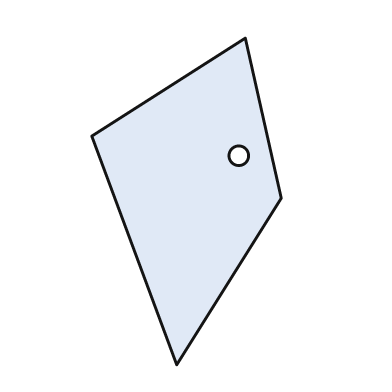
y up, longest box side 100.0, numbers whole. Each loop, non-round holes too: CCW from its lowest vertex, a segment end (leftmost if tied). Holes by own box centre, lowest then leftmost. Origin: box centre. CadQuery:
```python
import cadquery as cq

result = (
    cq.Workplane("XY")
    .moveTo(-3.0, -50.0)
    .lineTo(29.0, 1.0)
    .lineTo(18.0, 50.0)
    .lineTo(-29.0, 20.0)
    .close()
    .moveTo(16.0, 14.0)
    .circle(3.0)
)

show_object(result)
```